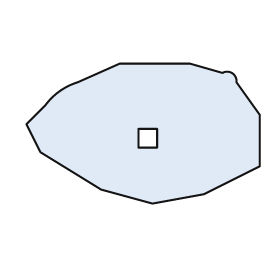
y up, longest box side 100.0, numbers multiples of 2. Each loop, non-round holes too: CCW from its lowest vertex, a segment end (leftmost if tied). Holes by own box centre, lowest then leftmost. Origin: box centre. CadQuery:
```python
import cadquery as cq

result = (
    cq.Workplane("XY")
    .moveTo(4.0, -30.0)
    .lineTo(26.0, -26.0)
    .lineTo(50.0, -14.0)
    .lineTo(50.0, 8.0)
    .lineTo(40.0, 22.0)
    .threePointArc((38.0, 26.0), (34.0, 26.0))
    .lineTo(20.0, 30.0)
    .lineTo(-10.0, 30.0)
    .lineTo(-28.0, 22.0)
    .threePointArc((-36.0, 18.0), (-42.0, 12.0))
    .lineTo(-50.0, 4.0)
    .lineTo(-44.0, -8.0)
    .lineTo(-18.0, -24.0)
    .close()
    .moveTo(-2.0, -6.0)
    .lineTo(6.0, -6.0)
    .lineTo(6.0, 2.0)
    .lineTo(-2.0, 2.0)
    .close()
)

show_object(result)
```